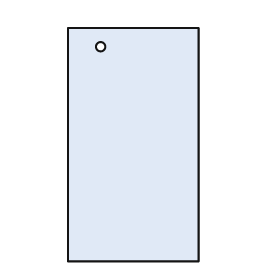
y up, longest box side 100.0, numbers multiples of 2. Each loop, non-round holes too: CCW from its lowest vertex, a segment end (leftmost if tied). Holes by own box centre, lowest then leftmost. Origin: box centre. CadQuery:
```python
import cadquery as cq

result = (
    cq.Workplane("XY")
    .moveTo(-28.0, -50.0)
    .lineTo(28.0, -50.0)
    .lineTo(28.0, 50.0)
    .lineTo(-28.0, 50.0)
    .close()
    .moveTo(-14.0, 42.0)
    .circle(2.0)
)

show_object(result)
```